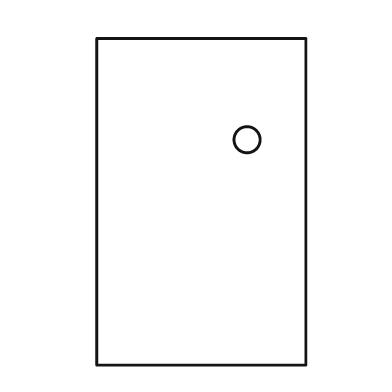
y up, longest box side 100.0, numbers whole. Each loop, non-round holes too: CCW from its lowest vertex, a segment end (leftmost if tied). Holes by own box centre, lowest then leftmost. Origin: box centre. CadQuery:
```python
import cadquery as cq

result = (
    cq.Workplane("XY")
    .moveTo(-32.0, -50.0)
    .lineTo(32.0, -50.0)
    .lineTo(32.0, 50.0)
    .lineTo(-32.0, 50.0)
    .close()
    .moveTo(14.0, 19.0)
    .circle(4.0)
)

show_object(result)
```